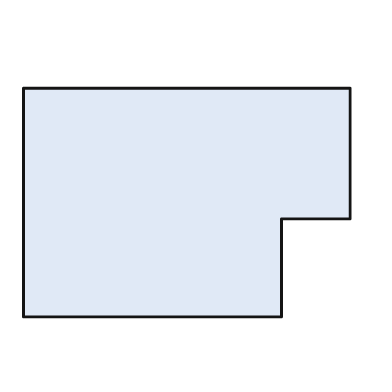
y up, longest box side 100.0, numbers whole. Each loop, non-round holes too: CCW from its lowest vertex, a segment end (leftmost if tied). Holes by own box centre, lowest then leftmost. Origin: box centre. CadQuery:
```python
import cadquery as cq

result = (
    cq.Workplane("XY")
    .moveTo(-50.0, -35.0)
    .lineTo(29.0, -35.0)
    .lineTo(29.0, -5.0)
    .lineTo(50.0, -5.0)
    .lineTo(50.0, 35.0)
    .lineTo(-50.0, 35.0)
    .close()
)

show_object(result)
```